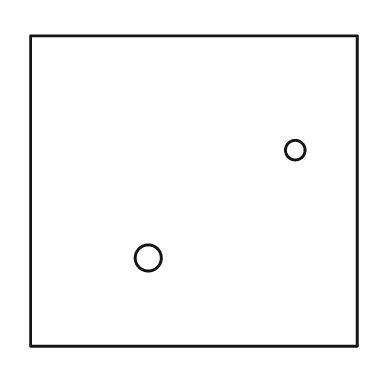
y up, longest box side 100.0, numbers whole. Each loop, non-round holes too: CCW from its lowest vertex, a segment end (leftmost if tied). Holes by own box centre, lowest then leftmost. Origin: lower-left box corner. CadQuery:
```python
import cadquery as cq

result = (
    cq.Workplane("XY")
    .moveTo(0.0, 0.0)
    .lineTo(100.0, 0.0)
    .lineTo(100.0, 95.0)
    .lineTo(0.0, 95.0)
    .close()
    .moveTo(36.0, 27.0)
    .circle(4.0)
    .moveTo(81.0, 60.0)
    .circle(3.0)
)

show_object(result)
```